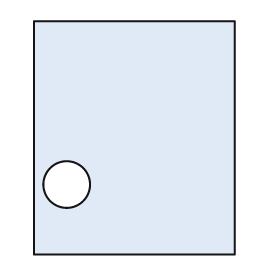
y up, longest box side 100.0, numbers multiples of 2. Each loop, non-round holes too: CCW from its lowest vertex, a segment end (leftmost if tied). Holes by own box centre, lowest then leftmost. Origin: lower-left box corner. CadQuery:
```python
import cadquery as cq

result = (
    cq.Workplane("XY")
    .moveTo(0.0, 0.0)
    .lineTo(86.0, 0.0)
    .lineTo(86.0, 100.0)
    .lineTo(0.0, 100.0)
    .close()
    .moveTo(14.0, 30.0)
    .circle(10.0)
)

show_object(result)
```